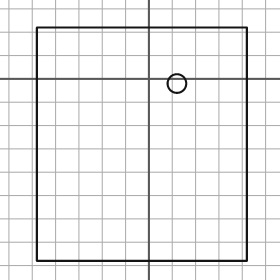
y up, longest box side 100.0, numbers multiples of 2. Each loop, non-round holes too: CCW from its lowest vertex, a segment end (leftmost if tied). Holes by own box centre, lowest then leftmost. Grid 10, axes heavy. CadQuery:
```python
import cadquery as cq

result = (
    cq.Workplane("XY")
    .moveTo(-48.0, -78.0)
    .lineTo(42.0, -78.0)
    .lineTo(42.0, 22.0)
    .lineTo(-48.0, 22.0)
    .close()
    .moveTo(12.0, -2.0)
    .circle(4.0)
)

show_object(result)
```